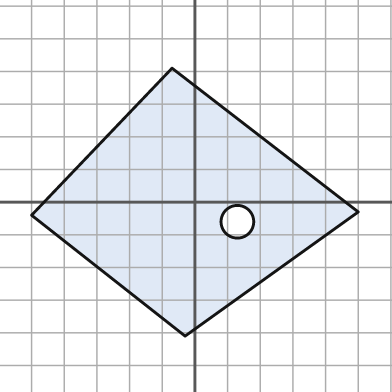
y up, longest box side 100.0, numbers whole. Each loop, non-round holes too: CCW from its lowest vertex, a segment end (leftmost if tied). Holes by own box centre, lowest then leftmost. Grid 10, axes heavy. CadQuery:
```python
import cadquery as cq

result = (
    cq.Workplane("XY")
    .moveTo(-3.0, -41.0)
    .lineTo(50.0, -3.0)
    .lineTo(-7.0, 41.0)
    .lineTo(-50.0, -4.0)
    .close()
    .moveTo(13.0, -6.0)
    .circle(5.0)
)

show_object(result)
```